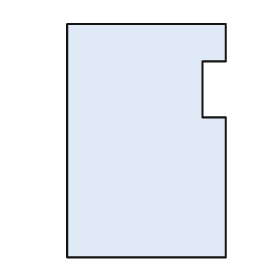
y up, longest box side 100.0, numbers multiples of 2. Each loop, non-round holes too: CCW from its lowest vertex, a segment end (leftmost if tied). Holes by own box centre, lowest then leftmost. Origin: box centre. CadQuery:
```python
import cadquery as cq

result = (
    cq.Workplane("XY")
    .moveTo(-34.0, -50.0)
    .lineTo(34.0, -50.0)
    .lineTo(34.0, 10.0)
    .lineTo(24.0, 10.0)
    .lineTo(24.0, 34.0)
    .lineTo(34.0, 34.0)
    .lineTo(34.0, 50.0)
    .lineTo(-34.0, 50.0)
    .close()
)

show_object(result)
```